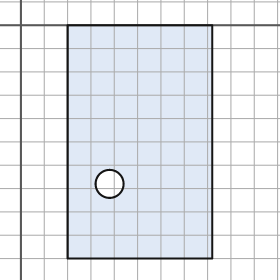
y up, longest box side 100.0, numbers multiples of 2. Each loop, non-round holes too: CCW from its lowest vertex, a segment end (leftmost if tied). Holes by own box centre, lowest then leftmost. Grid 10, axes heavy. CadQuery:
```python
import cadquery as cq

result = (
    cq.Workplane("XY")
    .moveTo(20.0, -100.0)
    .lineTo(82.0, -100.0)
    .lineTo(82.0, 0.0)
    .lineTo(20.0, 0.0)
    .close()
    .moveTo(38.0, -68.0)
    .circle(6.0)
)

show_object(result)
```